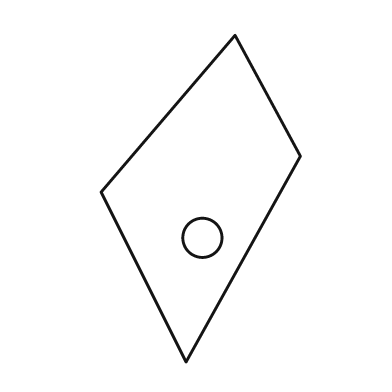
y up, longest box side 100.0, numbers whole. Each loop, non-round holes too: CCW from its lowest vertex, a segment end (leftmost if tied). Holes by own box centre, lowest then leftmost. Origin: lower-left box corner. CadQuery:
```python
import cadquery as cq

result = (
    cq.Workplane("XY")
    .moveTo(26.0, 0.0)
    .lineTo(61.0, 63.0)
    .lineTo(41.0, 100.0)
    .lineTo(0.0, 52.0)
    .close()
    .moveTo(31.0, 38.0)
    .circle(6.0)
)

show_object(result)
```